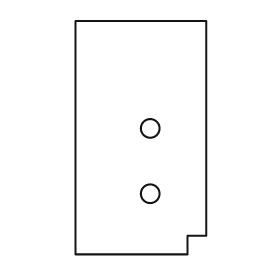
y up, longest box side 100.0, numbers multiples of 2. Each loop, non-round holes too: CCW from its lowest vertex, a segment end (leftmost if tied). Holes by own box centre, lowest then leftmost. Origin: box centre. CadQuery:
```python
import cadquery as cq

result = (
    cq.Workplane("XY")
    .moveTo(-28.0, -50.0)
    .lineTo(20.0, -50.0)
    .lineTo(20.0, -42.0)
    .lineTo(28.0, -42.0)
    .lineTo(28.0, 50.0)
    .lineTo(-28.0, 50.0)
    .close()
    .moveTo(4.0, -24.0)
    .circle(4.0)
    .moveTo(4.0, 4.0)
    .circle(4.0)
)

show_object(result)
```